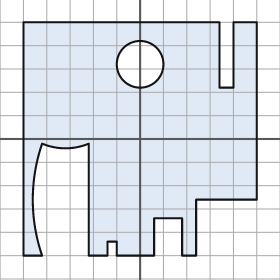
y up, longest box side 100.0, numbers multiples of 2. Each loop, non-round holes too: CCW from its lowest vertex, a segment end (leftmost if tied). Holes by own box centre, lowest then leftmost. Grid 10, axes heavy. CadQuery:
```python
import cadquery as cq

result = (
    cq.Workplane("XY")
    .moveTo(-50.0, -50.0)
    .lineTo(-42.0, -50.0)
    .threePointArc((-46.0, -26.0), (-42.0, -2.0))
    .threePointArc((-32.0, -4.0), (-22.0, -2.0))
    .lineTo(-22.0, -50.0)
    .lineTo(-14.0, -50.0)
    .lineTo(-14.0, -44.0)
    .lineTo(-10.0, -44.0)
    .lineTo(-10.0, -50.0)
    .lineTo(6.0, -50.0)
    .lineTo(6.0, -34.0)
    .lineTo(18.0, -34.0)
    .lineTo(18.0, -50.0)
    .lineTo(24.0, -50.0)
    .lineTo(24.0, -26.0)
    .lineTo(50.0, -26.0)
    .lineTo(50.0, 50.0)
    .lineTo(40.0, 50.0)
    .lineTo(40.0, 22.0)
    .lineTo(34.0, 22.0)
    .lineTo(34.0, 50.0)
    .lineTo(-50.0, 50.0)
    .close()
    .moveTo(0.0, 32.0)
    .circle(10.0)
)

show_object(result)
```